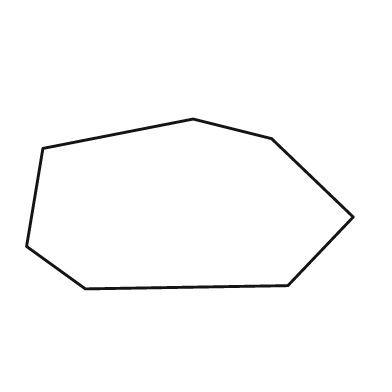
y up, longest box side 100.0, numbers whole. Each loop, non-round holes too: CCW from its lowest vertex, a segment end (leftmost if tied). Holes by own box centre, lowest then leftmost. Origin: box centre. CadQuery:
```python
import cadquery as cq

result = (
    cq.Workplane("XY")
    .moveTo(-32.0, -26.0)
    .lineTo(30.0, -25.0)
    .lineTo(50.0, -4.0)
    .lineTo(25.0, 20.0)
    .lineTo(1.0, 26.0)
    .lineTo(-45.0, 17.0)
    .lineTo(-50.0, -13.0)
    .close()
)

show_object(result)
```